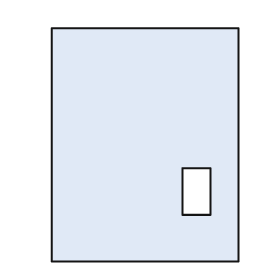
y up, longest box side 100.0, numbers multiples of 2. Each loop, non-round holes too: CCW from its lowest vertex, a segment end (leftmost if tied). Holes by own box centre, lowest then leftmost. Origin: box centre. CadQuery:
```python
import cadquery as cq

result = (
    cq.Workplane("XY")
    .moveTo(-40.0, -50.0)
    .lineTo(40.0, -50.0)
    .lineTo(40.0, 50.0)
    .lineTo(-40.0, 50.0)
    .close()
    .moveTo(16.0, -30.0)
    .lineTo(28.0, -30.0)
    .lineTo(28.0, -10.0)
    .lineTo(16.0, -10.0)
    .close()
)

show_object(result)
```